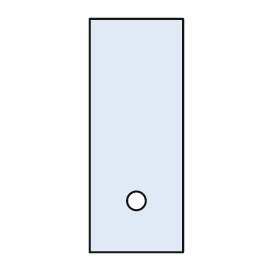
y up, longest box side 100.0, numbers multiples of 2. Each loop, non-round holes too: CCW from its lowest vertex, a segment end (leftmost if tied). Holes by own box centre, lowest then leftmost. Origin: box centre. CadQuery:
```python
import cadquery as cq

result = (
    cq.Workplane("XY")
    .moveTo(-20.0, -50.0)
    .lineTo(20.0, -50.0)
    .lineTo(20.0, 50.0)
    .lineTo(-20.0, 50.0)
    .close()
    .moveTo(0.0, -28.0)
    .circle(4.0)
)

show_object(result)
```